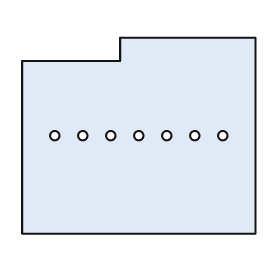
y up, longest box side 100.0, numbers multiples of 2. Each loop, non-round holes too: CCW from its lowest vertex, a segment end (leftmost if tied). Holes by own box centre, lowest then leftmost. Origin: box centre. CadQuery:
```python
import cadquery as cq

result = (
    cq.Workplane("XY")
    .moveTo(-50.0, -42.0)
    .lineTo(50.0, -42.0)
    .lineTo(50.0, 42.0)
    .lineTo(-8.0, 42.0)
    .lineTo(-8.0, 32.0)
    .lineTo(-50.0, 32.0)
    .close()
    .moveTo(-36.0, 0.0)
    .circle(2.0)
    .moveTo(-24.0, 0.0)
    .circle(2.0)
    .moveTo(-12.0, 0.0)
    .circle(2.0)
    .moveTo(0.0, 0.0)
    .circle(2.0)
    .moveTo(12.0, 0.0)
    .circle(2.0)
    .moveTo(24.0, 0.0)
    .circle(2.0)
    .moveTo(36.0, 0.0)
    .circle(2.0)
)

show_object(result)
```